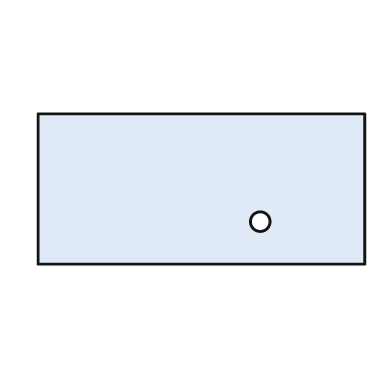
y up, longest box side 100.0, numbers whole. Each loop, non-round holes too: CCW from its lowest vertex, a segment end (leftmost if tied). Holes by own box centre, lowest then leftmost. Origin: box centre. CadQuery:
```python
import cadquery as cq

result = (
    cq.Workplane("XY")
    .moveTo(-50.0, -23.0)
    .lineTo(50.0, -23.0)
    .lineTo(50.0, 23.0)
    .lineTo(-50.0, 23.0)
    .close()
    .moveTo(18.0, -10.0)
    .circle(3.0)
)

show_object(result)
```